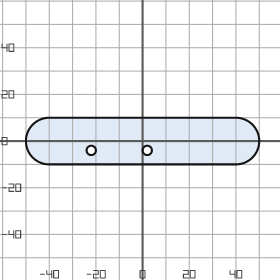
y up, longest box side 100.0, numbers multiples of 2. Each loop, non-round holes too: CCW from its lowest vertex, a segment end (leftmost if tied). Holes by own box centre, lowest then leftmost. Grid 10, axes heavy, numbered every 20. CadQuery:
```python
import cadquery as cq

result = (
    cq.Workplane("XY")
    .moveTo(-40.0, -10.0)
    .lineTo(40.0, -10.0)
    .threePointArc((50.0, 0.0), (40.0, 10.0))
    .lineTo(-40.0, 10.0)
    .threePointArc((-50.0, 0.0), (-40.0, -10.0))
    .close()
    .moveTo(-22.0, -4.0)
    .circle(2.0)
    .moveTo(2.0, -4.0)
    .circle(2.0)
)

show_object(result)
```